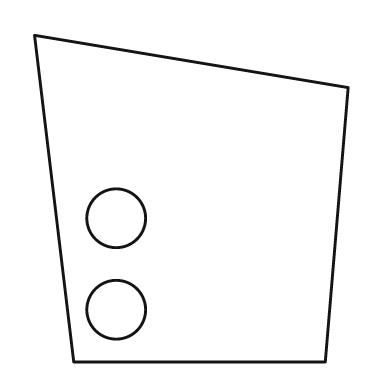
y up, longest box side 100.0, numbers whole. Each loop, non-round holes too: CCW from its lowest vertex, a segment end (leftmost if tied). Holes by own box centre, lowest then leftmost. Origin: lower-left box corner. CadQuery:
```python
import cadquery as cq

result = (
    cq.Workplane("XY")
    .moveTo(12.0, 0.0)
    .lineTo(89.0, 0.0)
    .lineTo(96.0, 84.0)
    .lineTo(0.0, 100.0)
    .close()
    .moveTo(25.0, 16.0)
    .circle(9.0)
    .moveTo(25.0, 44.0)
    .circle(9.0)
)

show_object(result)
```